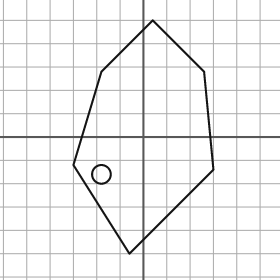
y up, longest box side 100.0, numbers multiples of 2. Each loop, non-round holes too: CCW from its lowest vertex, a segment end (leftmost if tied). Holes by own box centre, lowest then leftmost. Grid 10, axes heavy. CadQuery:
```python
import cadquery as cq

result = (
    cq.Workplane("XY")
    .moveTo(-6.0, -50.0)
    .lineTo(30.0, -14.0)
    .lineTo(26.0, 28.0)
    .lineTo(4.0, 50.0)
    .lineTo(-18.0, 28.0)
    .lineTo(-30.0, -12.0)
    .close()
    .moveTo(-18.0, -16.0)
    .circle(4.0)
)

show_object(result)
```